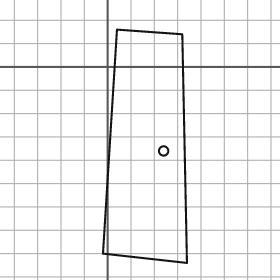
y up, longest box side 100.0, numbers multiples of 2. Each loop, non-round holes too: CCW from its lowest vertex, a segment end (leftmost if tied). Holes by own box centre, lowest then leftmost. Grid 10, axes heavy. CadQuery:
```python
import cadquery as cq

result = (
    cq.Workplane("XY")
    .moveTo(34.0, -84.0)
    .lineTo(32.0, 14.0)
    .lineTo(4.0, 16.0)
    .lineTo(-2.0, -80.0)
    .close()
    .moveTo(24.0, -36.0)
    .circle(2.0)
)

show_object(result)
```